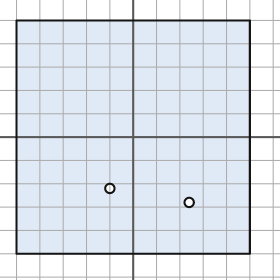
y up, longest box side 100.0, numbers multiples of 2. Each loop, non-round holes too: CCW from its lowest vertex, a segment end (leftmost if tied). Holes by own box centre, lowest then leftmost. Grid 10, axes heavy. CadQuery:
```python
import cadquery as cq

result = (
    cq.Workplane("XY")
    .moveTo(-50.0, -50.0)
    .lineTo(50.0, -50.0)
    .lineTo(50.0, 50.0)
    .lineTo(-50.0, 50.0)
    .close()
    .moveTo(24.0, -28.0)
    .circle(2.0)
    .moveTo(-10.0, -22.0)
    .circle(2.0)
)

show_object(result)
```